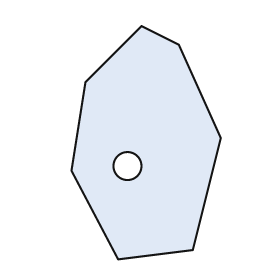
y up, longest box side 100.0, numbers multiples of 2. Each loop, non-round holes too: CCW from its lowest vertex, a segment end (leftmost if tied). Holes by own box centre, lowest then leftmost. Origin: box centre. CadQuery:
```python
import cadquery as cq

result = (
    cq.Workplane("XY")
    .moveTo(-12.0, -50.0)
    .lineTo(20.0, -46.0)
    .lineTo(32.0, 2.0)
    .lineTo(14.0, 42.0)
    .lineTo(-2.0, 50.0)
    .lineTo(-26.0, 26.0)
    .lineTo(-32.0, -12.0)
    .close()
    .moveTo(-8.0, -10.0)
    .circle(6.0)
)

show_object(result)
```